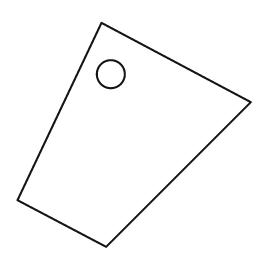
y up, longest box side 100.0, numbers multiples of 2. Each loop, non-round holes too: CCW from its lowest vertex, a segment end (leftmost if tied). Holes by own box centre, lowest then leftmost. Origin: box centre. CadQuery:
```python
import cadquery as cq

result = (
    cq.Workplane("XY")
    .moveTo(-12.0, -48.0)
    .lineTo(50.0, 14.0)
    .lineTo(-14.0, 48.0)
    .lineTo(-50.0, -28.0)
    .close()
    .moveTo(-10.0, 26.0)
    .circle(6.0)
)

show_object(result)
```